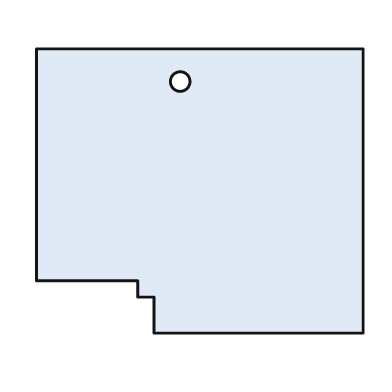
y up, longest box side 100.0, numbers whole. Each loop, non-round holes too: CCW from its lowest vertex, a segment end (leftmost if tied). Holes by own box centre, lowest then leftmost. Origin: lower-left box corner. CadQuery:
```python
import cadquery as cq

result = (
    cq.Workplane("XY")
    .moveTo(36.0, 0.0)
    .lineTo(100.0, 0.0)
    .lineTo(100.0, 87.0)
    .lineTo(0.0, 87.0)
    .lineTo(0.0, 16.0)
    .lineTo(31.0, 16.0)
    .lineTo(31.0, 11.0)
    .lineTo(36.0, 11.0)
    .close()
    .moveTo(44.0, 77.0)
    .circle(3.0)
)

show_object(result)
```